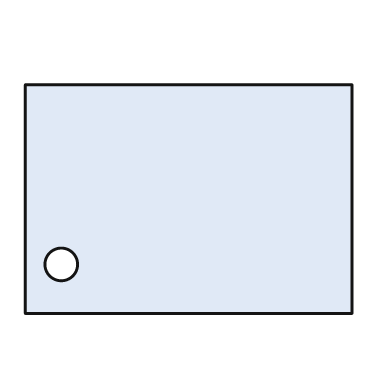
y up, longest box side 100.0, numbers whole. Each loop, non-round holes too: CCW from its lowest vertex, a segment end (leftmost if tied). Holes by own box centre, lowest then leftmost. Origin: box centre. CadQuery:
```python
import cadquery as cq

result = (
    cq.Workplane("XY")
    .moveTo(-50.0, -35.0)
    .lineTo(50.0, -35.0)
    .lineTo(50.0, 35.0)
    .lineTo(-50.0, 35.0)
    .close()
    .moveTo(-39.0, -20.0)
    .circle(5.0)
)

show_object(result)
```